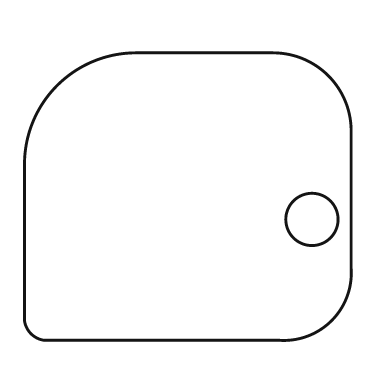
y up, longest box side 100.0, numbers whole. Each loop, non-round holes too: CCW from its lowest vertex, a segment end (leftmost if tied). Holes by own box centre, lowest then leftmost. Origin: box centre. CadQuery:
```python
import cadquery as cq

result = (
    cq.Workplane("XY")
    .moveTo(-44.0, -44.0)
    .lineTo(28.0, -44.0)
    .threePointArc((44.0, -38.0), (50.0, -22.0))
    .lineTo(50.0, 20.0)
    .threePointArc((43.0, 37.0), (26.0, 44.0))
    .lineTo(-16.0, 44.0)
    .threePointArc((-40.0, 34.0), (-50.0, 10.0))
    .lineTo(-50.0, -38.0)
    .threePointArc((-48.0, -42.0), (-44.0, -44.0))
    .close()
    .moveTo(38.0, -7.0)
    .circle(8.0)
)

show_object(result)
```